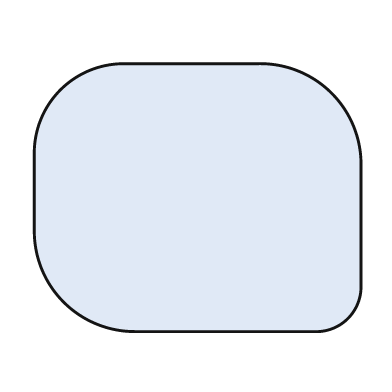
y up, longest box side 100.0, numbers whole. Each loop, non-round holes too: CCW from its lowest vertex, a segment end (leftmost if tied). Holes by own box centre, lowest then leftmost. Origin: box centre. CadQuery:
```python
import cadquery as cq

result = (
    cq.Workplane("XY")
    .moveTo(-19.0, -41.0)
    .lineTo(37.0, -41.0)
    .threePointArc((46.0, -37.0), (50.0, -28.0))
    .lineTo(50.0, 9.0)
    .threePointArc((41.0, 32.0), (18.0, 41.0))
    .lineTo(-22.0, 41.0)
    .threePointArc((-42.0, 33.0), (-50.0, 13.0))
    .lineTo(-50.0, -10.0)
    .threePointArc((-41.0, -32.0), (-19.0, -41.0))
    .close()
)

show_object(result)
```